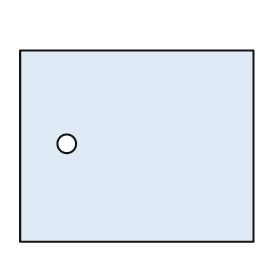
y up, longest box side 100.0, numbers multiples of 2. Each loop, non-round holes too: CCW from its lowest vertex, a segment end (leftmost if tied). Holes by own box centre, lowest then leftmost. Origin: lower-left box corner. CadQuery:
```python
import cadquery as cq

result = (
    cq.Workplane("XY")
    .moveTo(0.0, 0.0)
    .lineTo(100.0, 0.0)
    .lineTo(100.0, 82.0)
    .lineTo(0.0, 82.0)
    .close()
    .moveTo(20.0, 42.0)
    .circle(4.0)
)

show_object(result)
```